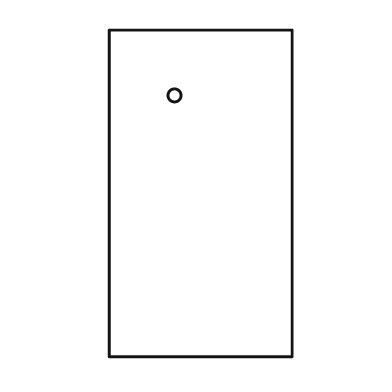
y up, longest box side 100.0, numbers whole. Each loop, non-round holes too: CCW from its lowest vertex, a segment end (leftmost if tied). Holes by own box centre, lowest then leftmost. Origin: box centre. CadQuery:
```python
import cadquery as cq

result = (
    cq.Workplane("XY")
    .moveTo(-28.0, -50.0)
    .lineTo(28.0, -50.0)
    .lineTo(28.0, 50.0)
    .lineTo(-28.0, 50.0)
    .close()
    .moveTo(-8.0, 30.0)
    .circle(2.0)
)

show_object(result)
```